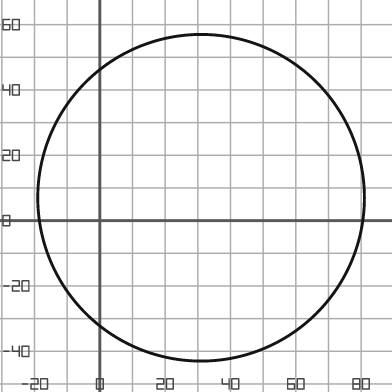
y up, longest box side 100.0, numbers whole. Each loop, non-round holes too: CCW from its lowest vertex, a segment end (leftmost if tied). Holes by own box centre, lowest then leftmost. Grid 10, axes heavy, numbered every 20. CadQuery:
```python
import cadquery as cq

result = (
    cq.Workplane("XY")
    .moveTo(31.0, 7.0)
    .circle(50.0)
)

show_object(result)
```